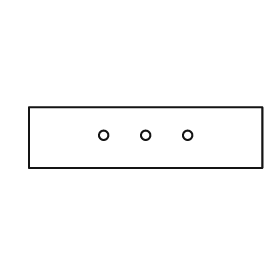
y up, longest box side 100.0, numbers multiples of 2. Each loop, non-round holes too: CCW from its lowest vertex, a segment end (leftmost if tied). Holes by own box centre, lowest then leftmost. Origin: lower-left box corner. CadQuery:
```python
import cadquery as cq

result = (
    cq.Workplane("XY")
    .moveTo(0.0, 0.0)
    .lineTo(100.0, 0.0)
    .lineTo(100.0, 26.0)
    .lineTo(0.0, 26.0)
    .close()
    .moveTo(32.0, 14.0)
    .circle(2.0)
    .moveTo(50.0, 14.0)
    .circle(2.0)
    .moveTo(68.0, 14.0)
    .circle(2.0)
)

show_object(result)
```